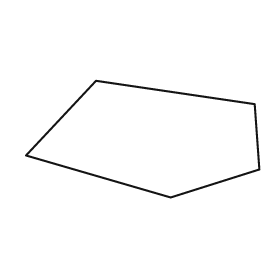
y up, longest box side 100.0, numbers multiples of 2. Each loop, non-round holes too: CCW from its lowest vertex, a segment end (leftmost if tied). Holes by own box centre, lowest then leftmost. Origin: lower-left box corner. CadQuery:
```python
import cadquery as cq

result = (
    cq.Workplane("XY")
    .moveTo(62.0, 0.0)
    .lineTo(100.0, 12.0)
    .lineTo(98.0, 40.0)
    .lineTo(30.0, 50.0)
    .lineTo(0.0, 18.0)
    .close()
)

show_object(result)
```